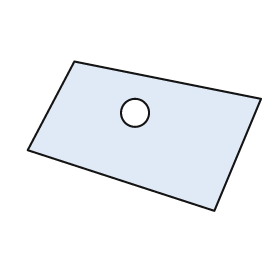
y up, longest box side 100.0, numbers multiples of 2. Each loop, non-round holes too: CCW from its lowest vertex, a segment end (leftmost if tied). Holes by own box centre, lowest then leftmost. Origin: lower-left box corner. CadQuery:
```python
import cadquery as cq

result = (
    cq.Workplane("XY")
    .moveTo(80.0, 0.0)
    .lineTo(100.0, 48.0)
    .lineTo(20.0, 64.0)
    .lineTo(0.0, 26.0)
    .close()
    .moveTo(46.0, 42.0)
    .circle(6.0)
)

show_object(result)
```